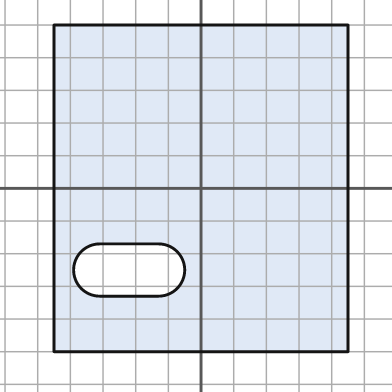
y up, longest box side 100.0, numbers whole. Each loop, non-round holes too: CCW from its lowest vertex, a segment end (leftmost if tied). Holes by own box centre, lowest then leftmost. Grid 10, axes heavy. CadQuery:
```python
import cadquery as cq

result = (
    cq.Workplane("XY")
    .moveTo(-45.0, -50.0)
    .lineTo(45.0, -50.0)
    .lineTo(45.0, 50.0)
    .lineTo(-45.0, 50.0)
    .close()
    .moveTo(-31.0, -33.0)
    .lineTo(-13.0, -33.0)
    .threePointArc((-5.0, -25.0), (-13.0, -17.0))
    .lineTo(-31.0, -17.0)
    .threePointArc((-39.0, -25.0), (-31.0, -33.0))
    .close()
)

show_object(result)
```